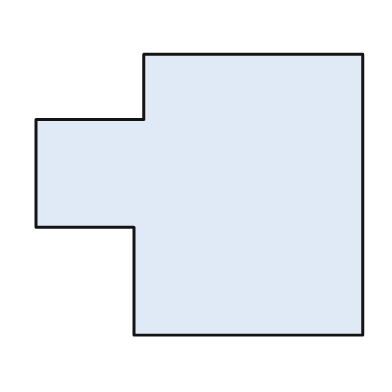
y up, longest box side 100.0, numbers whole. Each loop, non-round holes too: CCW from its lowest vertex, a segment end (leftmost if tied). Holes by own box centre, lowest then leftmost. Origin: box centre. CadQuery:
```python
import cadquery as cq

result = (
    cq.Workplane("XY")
    .moveTo(-20.0, -43.0)
    .lineTo(50.0, -43.0)
    .lineTo(50.0, 43.0)
    .lineTo(-17.0, 43.0)
    .lineTo(-17.0, 23.0)
    .lineTo(-50.0, 23.0)
    .lineTo(-50.0, -10.0)
    .lineTo(-20.0, -10.0)
    .close()
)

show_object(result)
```